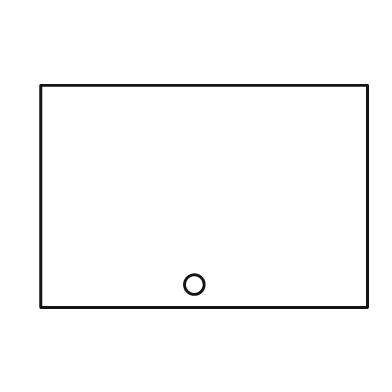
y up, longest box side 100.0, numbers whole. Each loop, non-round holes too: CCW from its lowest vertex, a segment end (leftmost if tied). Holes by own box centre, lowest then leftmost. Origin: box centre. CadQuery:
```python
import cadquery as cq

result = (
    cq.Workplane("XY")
    .moveTo(-50.0, -34.0)
    .lineTo(50.0, -34.0)
    .lineTo(50.0, 34.0)
    .lineTo(-50.0, 34.0)
    .close()
    .moveTo(-3.0, -27.0)
    .circle(3.0)
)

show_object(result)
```